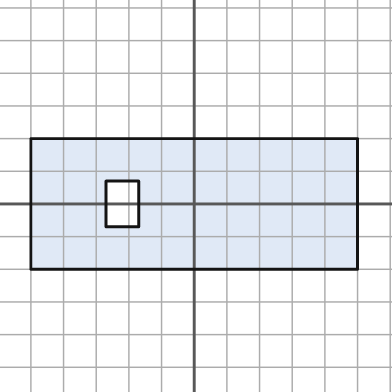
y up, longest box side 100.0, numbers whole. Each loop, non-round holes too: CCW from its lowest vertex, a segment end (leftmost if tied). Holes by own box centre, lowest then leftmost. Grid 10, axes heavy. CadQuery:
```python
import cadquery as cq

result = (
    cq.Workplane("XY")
    .moveTo(-50.0, -20.0)
    .lineTo(50.0, -20.0)
    .lineTo(50.0, 20.0)
    .lineTo(-50.0, 20.0)
    .close()
    .moveTo(-27.0, -7.0)
    .lineTo(-17.0, -7.0)
    .lineTo(-17.0, 7.0)
    .lineTo(-27.0, 7.0)
    .close()
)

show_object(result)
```